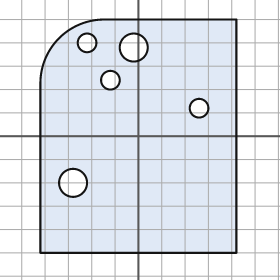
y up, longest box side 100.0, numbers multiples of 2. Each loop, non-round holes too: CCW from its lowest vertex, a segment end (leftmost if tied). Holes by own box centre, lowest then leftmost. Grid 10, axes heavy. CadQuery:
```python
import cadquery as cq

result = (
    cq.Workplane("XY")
    .moveTo(-42.0, -50.0)
    .lineTo(42.0, -50.0)
    .lineTo(42.0, 50.0)
    .lineTo(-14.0, 50.0)
    .threePointArc((-34.0, 42.0), (-42.0, 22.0))
    .close()
    .moveTo(-28.0, -20.0)
    .circle(6.0)
    .moveTo(26.0, 12.0)
    .circle(4.0)
    .moveTo(-12.0, 24.0)
    .circle(4.0)
    .moveTo(-2.0, 38.0)
    .circle(6.0)
    .moveTo(-22.0, 40.0)
    .circle(4.0)
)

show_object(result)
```